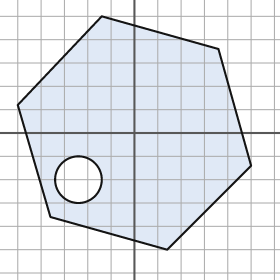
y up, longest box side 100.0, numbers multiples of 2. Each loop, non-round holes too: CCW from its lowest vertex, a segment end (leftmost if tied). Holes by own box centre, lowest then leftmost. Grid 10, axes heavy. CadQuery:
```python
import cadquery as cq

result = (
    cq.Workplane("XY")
    .moveTo(14.0, -50.0)
    .lineTo(50.0, -14.0)
    .lineTo(36.0, 36.0)
    .lineTo(-14.0, 50.0)
    .lineTo(-50.0, 12.0)
    .lineTo(-36.0, -36.0)
    .close()
    .moveTo(-24.0, -20.0)
    .circle(10.0)
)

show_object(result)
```